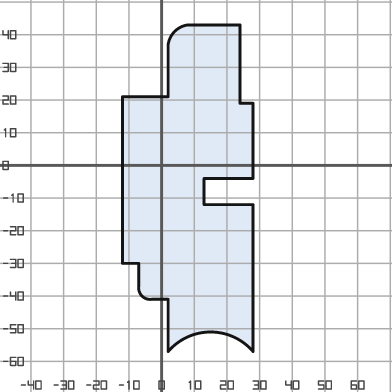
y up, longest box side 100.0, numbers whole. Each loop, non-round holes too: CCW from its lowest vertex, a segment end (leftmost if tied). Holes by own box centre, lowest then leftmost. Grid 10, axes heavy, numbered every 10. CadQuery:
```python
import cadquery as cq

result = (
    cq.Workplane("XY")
    .moveTo(2.0, -57.0)
    .threePointArc((15.0, -51.0), (28.0, -57.0))
    .lineTo(28.0, -12.0)
    .lineTo(13.0, -12.0)
    .lineTo(13.0, -4.0)
    .lineTo(28.0, -4.0)
    .lineTo(28.0, 19.0)
    .lineTo(24.0, 19.0)
    .lineTo(24.0, 43.0)
    .lineTo(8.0, 43.0)
    .threePointArc((4.0, 41.0), (2.0, 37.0))
    .lineTo(2.0, 21.0)
    .lineTo(-12.0, 21.0)
    .lineTo(-12.0, -30.0)
    .lineTo(-7.0, -30.0)
    .lineTo(-7.0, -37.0)
    .threePointArc((-6.0, -40.0), (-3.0, -41.0))
    .lineTo(2.0, -41.0)
    .close()
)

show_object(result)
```